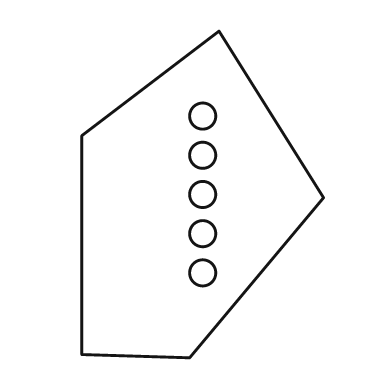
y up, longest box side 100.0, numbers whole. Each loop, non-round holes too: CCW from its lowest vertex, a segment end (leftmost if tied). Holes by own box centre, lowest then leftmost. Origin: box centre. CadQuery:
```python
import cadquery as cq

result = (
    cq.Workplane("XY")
    .moveTo(-4.0, -50.0)
    .lineTo(37.0, -1.0)
    .lineTo(5.0, 50.0)
    .lineTo(-37.0, 18.0)
    .lineTo(-37.0, -49.0)
    .close()
    .moveTo(0.0, -24.0)
    .circle(4.0)
    .moveTo(0.0, -12.0)
    .circle(4.0)
    .moveTo(0.0, 0.0)
    .circle(4.0)
    .moveTo(0.0, 12.0)
    .circle(4.0)
    .moveTo(0.0, 24.0)
    .circle(4.0)
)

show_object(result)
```